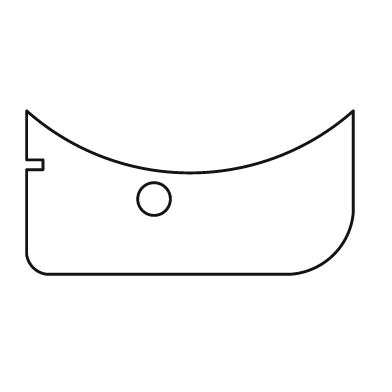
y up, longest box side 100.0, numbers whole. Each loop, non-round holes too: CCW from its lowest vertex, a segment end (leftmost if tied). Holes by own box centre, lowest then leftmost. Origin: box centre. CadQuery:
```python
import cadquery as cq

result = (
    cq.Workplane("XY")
    .moveTo(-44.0, -25.0)
    .lineTo(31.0, -25.0)
    .threePointArc((44.0, -19.0), (50.0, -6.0))
    .lineTo(50.0, 25.0)
    .threePointArc((0.0, 6.0), (-50.0, 25.0))
    .lineTo(-50.0, 10.0)
    .lineTo(-45.0, 10.0)
    .lineTo(-45.0, 7.0)
    .lineTo(-50.0, 7.0)
    .lineTo(-50.0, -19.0)
    .threePointArc((-48.0, -23.0), (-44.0, -25.0))
    .close()
    .moveTo(-11.0, -2.0)
    .circle(5.0)
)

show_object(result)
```